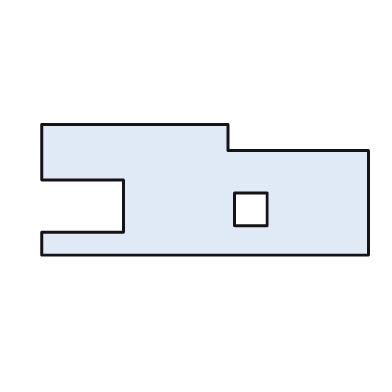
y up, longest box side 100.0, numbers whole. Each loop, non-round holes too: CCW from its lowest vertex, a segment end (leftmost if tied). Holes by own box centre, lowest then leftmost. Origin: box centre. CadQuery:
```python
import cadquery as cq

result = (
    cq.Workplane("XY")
    .moveTo(-50.0, -20.0)
    .lineTo(50.0, -20.0)
    .lineTo(50.0, 12.0)
    .lineTo(7.0, 12.0)
    .lineTo(7.0, 20.0)
    .lineTo(-50.0, 20.0)
    .lineTo(-50.0, 3.0)
    .lineTo(-25.0, 3.0)
    .lineTo(-25.0, -13.0)
    .lineTo(-50.0, -13.0)
    .close()
    .moveTo(9.0, -11.0)
    .lineTo(19.0, -11.0)
    .lineTo(19.0, -1.0)
    .lineTo(9.0, -1.0)
    .close()
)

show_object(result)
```